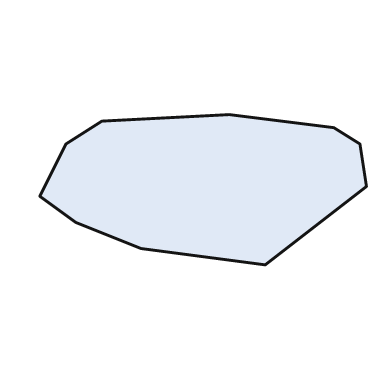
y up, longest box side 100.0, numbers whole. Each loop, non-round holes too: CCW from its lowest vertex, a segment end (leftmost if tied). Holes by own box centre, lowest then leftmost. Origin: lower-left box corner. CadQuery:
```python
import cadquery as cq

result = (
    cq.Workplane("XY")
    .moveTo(69.0, 0.0)
    .lineTo(100.0, 24.0)
    .lineTo(98.0, 37.0)
    .lineTo(90.0, 42.0)
    .lineTo(58.0, 46.0)
    .lineTo(19.0, 44.0)
    .lineTo(8.0, 37.0)
    .lineTo(0.0, 21.0)
    .lineTo(11.0, 13.0)
    .lineTo(31.0, 5.0)
    .close()
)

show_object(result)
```